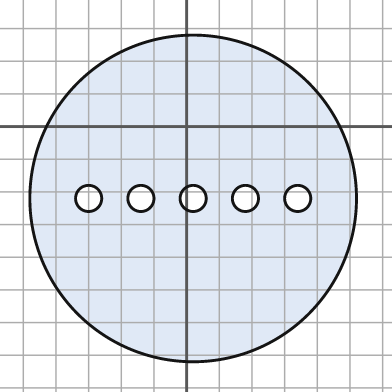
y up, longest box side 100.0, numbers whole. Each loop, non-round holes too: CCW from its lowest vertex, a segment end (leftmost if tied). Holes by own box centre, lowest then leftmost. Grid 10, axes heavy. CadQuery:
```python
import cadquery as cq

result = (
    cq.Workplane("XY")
    .moveTo(2.0, -22.0)
    .circle(50.0)
    .moveTo(-30.0, -22.0)
    .circle(4.0)
    .moveTo(-14.0, -22.0)
    .circle(4.0)
    .moveTo(2.0, -22.0)
    .circle(4.0)
    .moveTo(18.0, -22.0)
    .circle(4.0)
    .moveTo(34.0, -22.0)
    .circle(4.0)
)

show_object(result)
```